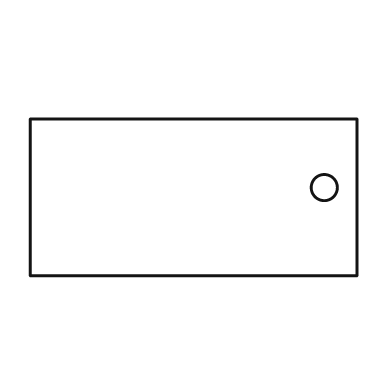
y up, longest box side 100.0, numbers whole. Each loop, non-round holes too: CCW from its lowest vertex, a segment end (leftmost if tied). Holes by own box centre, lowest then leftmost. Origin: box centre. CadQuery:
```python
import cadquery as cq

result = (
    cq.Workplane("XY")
    .moveTo(-50.0, -24.0)
    .lineTo(50.0, -24.0)
    .lineTo(50.0, 24.0)
    .lineTo(-50.0, 24.0)
    .close()
    .moveTo(40.0, 3.0)
    .circle(4.0)
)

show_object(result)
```